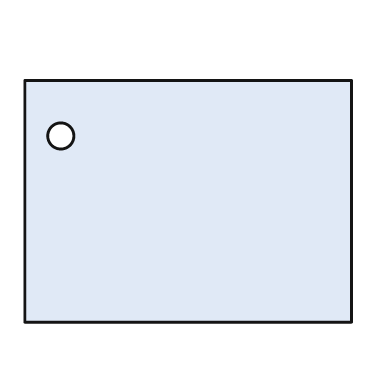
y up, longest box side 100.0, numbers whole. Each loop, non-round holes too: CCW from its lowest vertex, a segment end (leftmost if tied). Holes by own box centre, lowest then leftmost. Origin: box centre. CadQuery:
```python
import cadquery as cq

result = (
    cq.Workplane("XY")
    .moveTo(-50.0, -37.0)
    .lineTo(50.0, -37.0)
    .lineTo(50.0, 37.0)
    .lineTo(-50.0, 37.0)
    .close()
    .moveTo(-39.0, 20.0)
    .circle(4.0)
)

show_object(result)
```